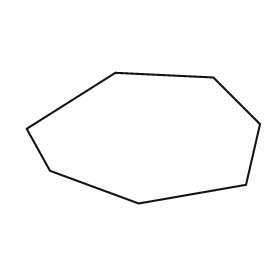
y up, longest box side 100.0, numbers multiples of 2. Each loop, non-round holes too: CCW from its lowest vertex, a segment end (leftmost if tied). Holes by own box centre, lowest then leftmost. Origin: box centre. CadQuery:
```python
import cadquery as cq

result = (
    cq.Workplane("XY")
    .moveTo(-2.0, -28.0)
    .lineTo(44.0, -20.0)
    .lineTo(50.0, 6.0)
    .lineTo(30.0, 26.0)
    .lineTo(-12.0, 28.0)
    .lineTo(-50.0, 4.0)
    .lineTo(-40.0, -14.0)
    .close()
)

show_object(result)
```